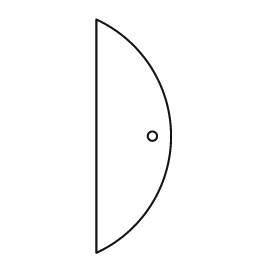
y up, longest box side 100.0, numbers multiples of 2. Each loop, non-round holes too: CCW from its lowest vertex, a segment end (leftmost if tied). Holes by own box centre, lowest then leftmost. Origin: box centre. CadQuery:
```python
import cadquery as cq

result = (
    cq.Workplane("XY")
    .moveTo(-16.0, -50.0)
    .threePointArc((16.0, 0.0), (-16.0, 50.0))
    .close()
    .moveTo(8.0, 0.0)
    .circle(2.0)
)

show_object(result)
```